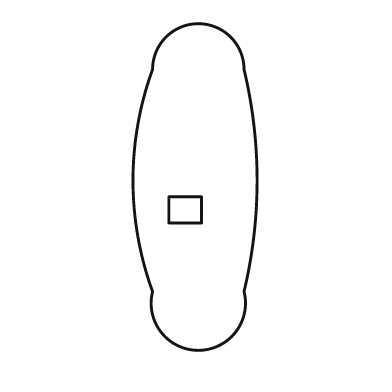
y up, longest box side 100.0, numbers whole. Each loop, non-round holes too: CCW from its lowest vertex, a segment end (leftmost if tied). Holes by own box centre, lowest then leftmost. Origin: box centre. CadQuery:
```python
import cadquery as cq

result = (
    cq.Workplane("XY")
    .moveTo(-13.0, -32.0)
    .threePointArc((1.0, -50.0), (15.0, -32.0))
    .threePointArc((19.0, 2.0), (15.0, 36.0))
    .threePointArc((1.0, 50.0), (-13.0, 36.0))
    .threePointArc((-19.0, 2.0), (-13.0, -32.0))
    .close()
    .moveTo(-8.0, -11.0)
    .lineTo(2.0, -11.0)
    .lineTo(2.0, -3.0)
    .lineTo(-8.0, -3.0)
    .close()
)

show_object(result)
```